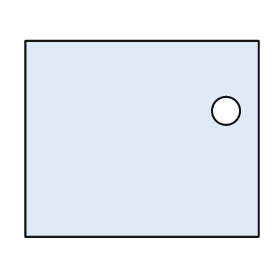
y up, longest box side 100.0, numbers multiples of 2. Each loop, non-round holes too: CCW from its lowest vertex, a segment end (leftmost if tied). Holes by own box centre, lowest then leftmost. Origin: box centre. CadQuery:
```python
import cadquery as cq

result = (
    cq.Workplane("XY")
    .moveTo(-50.0, -42.0)
    .lineTo(50.0, -42.0)
    .lineTo(50.0, 42.0)
    .lineTo(-50.0, 42.0)
    .close()
    .moveTo(36.0, 12.0)
    .circle(6.0)
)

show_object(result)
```